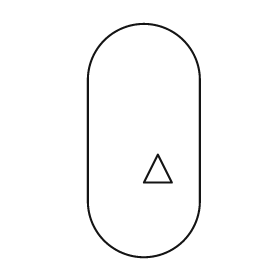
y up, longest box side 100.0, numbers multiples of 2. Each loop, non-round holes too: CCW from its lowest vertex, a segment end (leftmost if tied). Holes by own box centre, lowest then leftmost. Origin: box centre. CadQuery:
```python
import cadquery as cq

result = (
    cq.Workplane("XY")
    .moveTo(-24.0, -26.0)
    .threePointArc((0.0, -50.0), (24.0, -26.0))
    .lineTo(24.0, 26.0)
    .threePointArc((0.0, 50.0), (-24.0, 26.0))
    .close()
    .moveTo(0.0, -18.0)
    .lineTo(12.0, -18.0)
    .lineTo(6.0, -6.0)
    .close()
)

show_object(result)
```